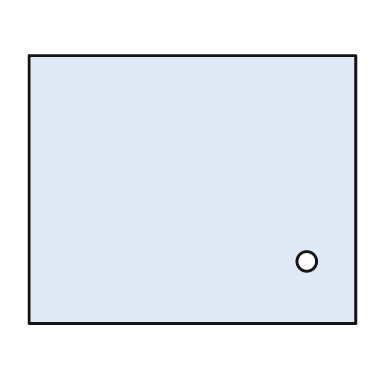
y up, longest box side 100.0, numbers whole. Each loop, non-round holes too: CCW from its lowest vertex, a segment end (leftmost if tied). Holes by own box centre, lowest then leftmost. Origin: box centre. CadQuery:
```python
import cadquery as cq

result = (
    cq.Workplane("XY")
    .moveTo(-50.0, -41.0)
    .lineTo(50.0, -41.0)
    .lineTo(50.0, 41.0)
    .lineTo(-50.0, 41.0)
    .close()
    .moveTo(35.0, -22.0)
    .circle(3.0)
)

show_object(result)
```